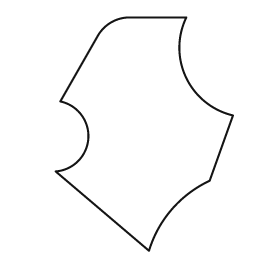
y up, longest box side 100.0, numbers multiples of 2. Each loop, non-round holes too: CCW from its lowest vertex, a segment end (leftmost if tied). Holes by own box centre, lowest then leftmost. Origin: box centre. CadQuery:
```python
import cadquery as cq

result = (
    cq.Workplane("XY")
    .moveTo(2.0, -50.0)
    .threePointArc((12.0, -32.0), (28.0, -20.0))
    .lineTo(38.0, 8.0)
    .threePointArc((18.0, 24.0), (18.0, 50.0))
    .lineTo(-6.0, 50.0)
    .threePointArc((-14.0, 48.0), (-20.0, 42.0))
    .lineTo(-36.0, 14.0)
    .threePointArc((-24.0, -2.0), (-38.0, -16.0))
    .close()
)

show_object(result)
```